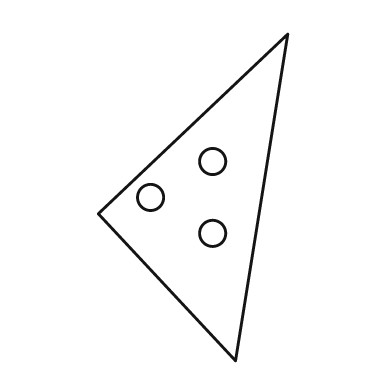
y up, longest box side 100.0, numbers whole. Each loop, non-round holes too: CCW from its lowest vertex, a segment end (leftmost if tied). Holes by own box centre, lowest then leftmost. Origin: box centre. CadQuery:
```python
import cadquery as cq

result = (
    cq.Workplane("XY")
    .moveTo(13.0, -50.0)
    .lineTo(29.0, 50.0)
    .lineTo(-29.0, -5.0)
    .close()
    .moveTo(6.0, -11.0)
    .circle(4.0)
    .moveTo(-13.0, 0.0)
    .circle(4.0)
    .moveTo(6.0, 11.0)
    .circle(4.0)
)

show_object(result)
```